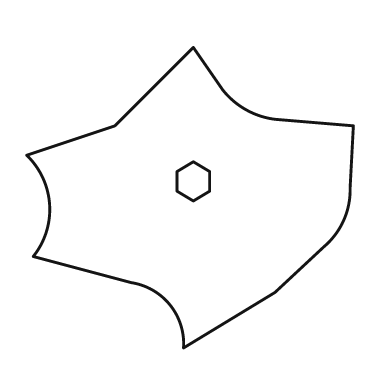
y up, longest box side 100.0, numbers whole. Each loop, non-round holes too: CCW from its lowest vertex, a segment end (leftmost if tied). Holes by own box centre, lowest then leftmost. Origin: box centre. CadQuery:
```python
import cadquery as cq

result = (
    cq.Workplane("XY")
    .moveTo(-2.0, -46.0)
    .lineTo(26.0, -29.0)
    .lineTo(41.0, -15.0)
    .threePointArc((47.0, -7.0), (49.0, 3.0))
    .lineTo(50.0, 22.0)
    .lineTo(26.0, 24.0)
    .threePointArc((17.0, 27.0), (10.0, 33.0))
    .lineTo(1.0, 46.0)
    .lineTo(-23.0, 22.0)
    .lineTo(-50.0, 13.0)
    .threePointArc((-43.0, -2.0), (-48.0, -18.0))
    .lineTo(-18.0, -26.0)
    .threePointArc((-6.0, -33.0), (-2.0, -46.0))
    .close()
    .moveTo(1.0, -1.0)
    .lineTo(6.0, 2.0)
    .lineTo(6.0, 8.0)
    .lineTo(1.0, 11.0)
    .lineTo(-4.0, 8.0)
    .lineTo(-4.0, 2.0)
    .close()
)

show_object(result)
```